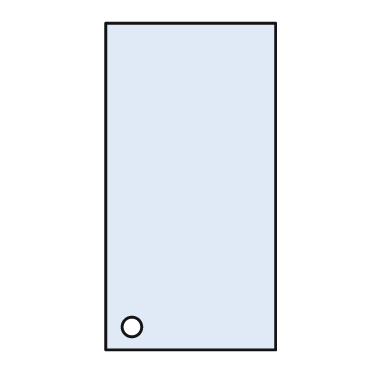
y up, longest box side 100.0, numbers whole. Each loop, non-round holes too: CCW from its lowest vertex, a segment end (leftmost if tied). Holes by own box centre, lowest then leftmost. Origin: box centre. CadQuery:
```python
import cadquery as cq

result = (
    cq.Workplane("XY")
    .moveTo(-26.0, -50.0)
    .lineTo(26.0, -50.0)
    .lineTo(26.0, 50.0)
    .lineTo(-26.0, 50.0)
    .close()
    .moveTo(-18.0, -43.0)
    .circle(3.0)
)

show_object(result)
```